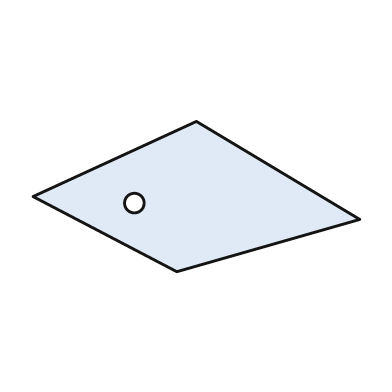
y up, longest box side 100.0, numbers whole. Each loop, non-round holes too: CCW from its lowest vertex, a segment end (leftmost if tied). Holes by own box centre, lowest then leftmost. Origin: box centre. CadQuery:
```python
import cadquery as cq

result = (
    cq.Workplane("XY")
    .moveTo(-6.0, -23.0)
    .lineTo(50.0, -7.0)
    .lineTo(0.0, 23.0)
    .lineTo(-50.0, 0.0)
    .close()
    .moveTo(-19.0, -2.0)
    .circle(3.0)
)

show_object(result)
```